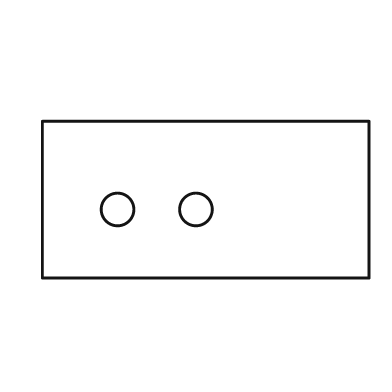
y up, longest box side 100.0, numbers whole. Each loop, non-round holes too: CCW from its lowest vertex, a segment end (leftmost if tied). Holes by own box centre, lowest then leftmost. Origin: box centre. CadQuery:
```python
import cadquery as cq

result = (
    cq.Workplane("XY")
    .moveTo(-50.0, -24.0)
    .lineTo(50.0, -24.0)
    .lineTo(50.0, 24.0)
    .lineTo(-50.0, 24.0)
    .close()
    .moveTo(-27.0, -3.0)
    .circle(5.0)
    .moveTo(-3.0, -3.0)
    .circle(5.0)
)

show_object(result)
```